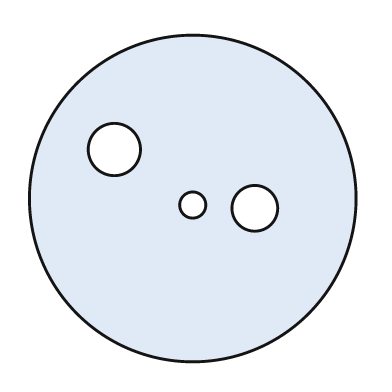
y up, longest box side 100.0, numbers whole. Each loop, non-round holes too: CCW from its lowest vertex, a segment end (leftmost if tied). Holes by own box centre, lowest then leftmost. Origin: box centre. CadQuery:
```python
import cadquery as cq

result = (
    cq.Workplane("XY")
    .moveTo(0.0, 0.0)
    .circle(50.0)
    .moveTo(19.0, -3.0)
    .circle(7.0)
    .moveTo(0.0, -2.0)
    .circle(4.0)
    .moveTo(-24.0, 15.0)
    .circle(8.0)
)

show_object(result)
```